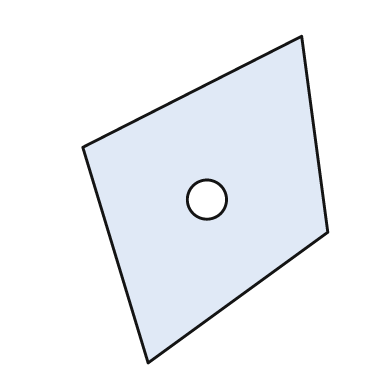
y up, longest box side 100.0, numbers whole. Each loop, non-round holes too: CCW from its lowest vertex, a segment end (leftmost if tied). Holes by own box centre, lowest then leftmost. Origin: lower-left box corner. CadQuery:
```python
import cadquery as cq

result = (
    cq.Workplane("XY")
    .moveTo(20.0, 0.0)
    .lineTo(75.0, 40.0)
    .lineTo(67.0, 100.0)
    .lineTo(0.0, 66.0)
    .close()
    .moveTo(38.0, 50.0)
    .circle(6.0)
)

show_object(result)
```